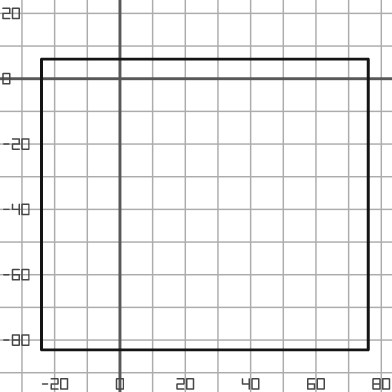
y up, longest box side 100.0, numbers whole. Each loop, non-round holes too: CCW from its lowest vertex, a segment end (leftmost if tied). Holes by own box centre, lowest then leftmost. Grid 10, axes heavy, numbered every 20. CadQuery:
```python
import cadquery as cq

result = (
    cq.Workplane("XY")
    .moveTo(-24.0, -83.0)
    .lineTo(76.0, -83.0)
    .lineTo(76.0, 6.0)
    .lineTo(-24.0, 6.0)
    .close()
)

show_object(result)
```